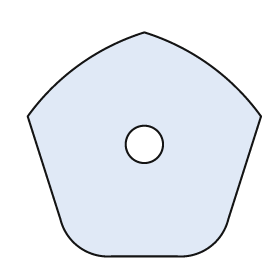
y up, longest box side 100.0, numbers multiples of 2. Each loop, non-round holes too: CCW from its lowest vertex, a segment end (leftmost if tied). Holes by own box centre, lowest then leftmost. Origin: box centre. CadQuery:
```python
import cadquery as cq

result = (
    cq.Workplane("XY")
    .moveTo(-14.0, -48.0)
    .lineTo(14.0, -48.0)
    .threePointArc((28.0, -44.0), (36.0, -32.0))
    .lineTo(50.0, 12.0)
    .threePointArc((28.0, 34.0), (0.0, 48.0))
    .threePointArc((-28.0, 34.0), (-50.0, 12.0))
    .lineTo(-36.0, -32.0)
    .threePointArc((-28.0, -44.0), (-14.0, -48.0))
    .close()
    .moveTo(0.0, 0.0)
    .circle(8.0)
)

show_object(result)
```